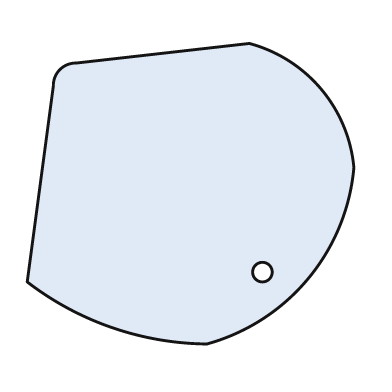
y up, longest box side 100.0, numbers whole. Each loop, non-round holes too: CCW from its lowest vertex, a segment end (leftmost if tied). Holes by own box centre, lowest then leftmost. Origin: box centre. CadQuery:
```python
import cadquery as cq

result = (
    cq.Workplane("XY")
    .moveTo(5.0, -46.0)
    .threePointArc((36.0, -26.0), (50.0, 8.0))
    .threePointArc((40.0, 32.0), (18.0, 46.0))
    .lineTo(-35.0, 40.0)
    .threePointArc((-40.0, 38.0), (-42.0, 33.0))
    .lineTo(-50.0, -27.0)
    .threePointArc((-24.0, -41.0), (5.0, -46.0))
    .close()
    .moveTo(22.0, -24.0)
    .circle(3.0)
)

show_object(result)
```